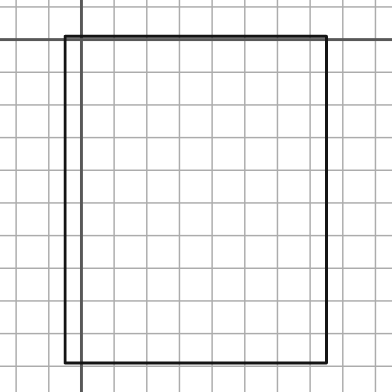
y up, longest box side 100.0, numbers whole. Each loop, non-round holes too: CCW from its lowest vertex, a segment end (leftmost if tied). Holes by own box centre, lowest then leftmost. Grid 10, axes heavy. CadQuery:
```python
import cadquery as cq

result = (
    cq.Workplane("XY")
    .moveTo(-5.0, -99.0)
    .lineTo(75.0, -99.0)
    .lineTo(75.0, 1.0)
    .lineTo(-5.0, 1.0)
    .close()
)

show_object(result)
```